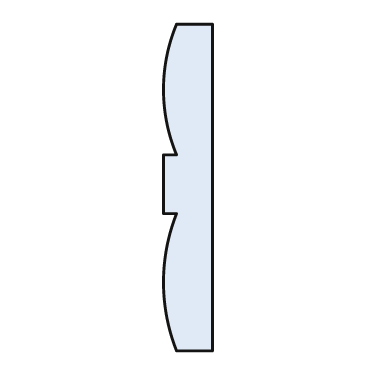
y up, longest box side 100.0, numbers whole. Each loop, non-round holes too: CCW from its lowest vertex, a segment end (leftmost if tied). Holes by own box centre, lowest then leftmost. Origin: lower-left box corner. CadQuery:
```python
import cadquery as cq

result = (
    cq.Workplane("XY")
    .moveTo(4.0, 0.0)
    .lineTo(15.0, 0.0)
    .lineTo(15.0, 100.0)
    .lineTo(4.0, 100.0)
    .threePointArc((0.0, 80.0), (4.0, 60.0))
    .lineTo(0.0, 60.0)
    .lineTo(0.0, 42.0)
    .lineTo(4.0, 42.0)
    .threePointArc((0.0, 21.0), (4.0, 0.0))
    .close()
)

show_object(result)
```